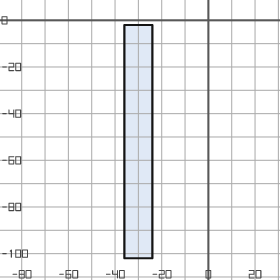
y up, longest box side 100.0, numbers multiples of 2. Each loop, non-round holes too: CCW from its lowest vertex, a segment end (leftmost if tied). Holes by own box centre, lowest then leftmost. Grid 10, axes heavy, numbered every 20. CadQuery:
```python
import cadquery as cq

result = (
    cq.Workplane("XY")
    .moveTo(-36.0, -102.0)
    .lineTo(-24.0, -102.0)
    .lineTo(-24.0, -2.0)
    .lineTo(-36.0, -2.0)
    .close()
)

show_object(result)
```